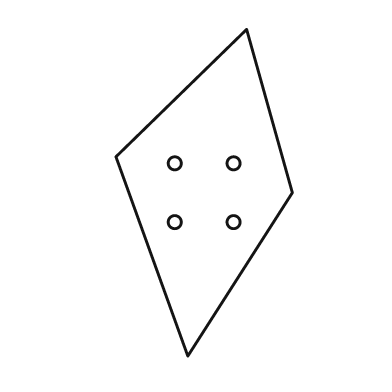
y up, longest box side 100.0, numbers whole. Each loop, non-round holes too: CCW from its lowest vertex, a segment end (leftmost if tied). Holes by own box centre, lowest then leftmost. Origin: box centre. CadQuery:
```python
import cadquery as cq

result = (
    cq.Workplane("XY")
    .moveTo(-5.0, -50.0)
    .lineTo(27.0, 0.0)
    .lineTo(13.0, 50.0)
    .lineTo(-27.0, 11.0)
    .close()
    .moveTo(-9.0, -9.0)
    .circle(2.0)
    .moveTo(9.0, -9.0)
    .circle(2.0)
    .moveTo(-9.0, 9.0)
    .circle(2.0)
    .moveTo(9.0, 9.0)
    .circle(2.0)
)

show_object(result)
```